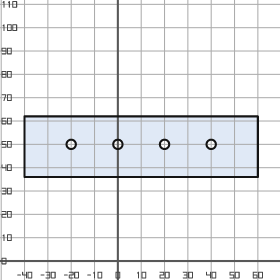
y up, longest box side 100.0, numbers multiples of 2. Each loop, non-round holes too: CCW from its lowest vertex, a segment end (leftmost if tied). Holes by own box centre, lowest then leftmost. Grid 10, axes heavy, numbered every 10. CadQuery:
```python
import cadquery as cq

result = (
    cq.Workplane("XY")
    .moveTo(-40.0, 36.0)
    .lineTo(60.0, 36.0)
    .lineTo(60.0, 62.0)
    .lineTo(-40.0, 62.0)
    .close()
    .moveTo(-20.0, 50.0)
    .circle(2.0)
    .moveTo(0.0, 50.0)
    .circle(2.0)
    .moveTo(20.0, 50.0)
    .circle(2.0)
    .moveTo(40.0, 50.0)
    .circle(2.0)
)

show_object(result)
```